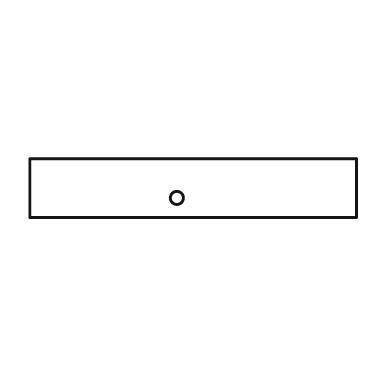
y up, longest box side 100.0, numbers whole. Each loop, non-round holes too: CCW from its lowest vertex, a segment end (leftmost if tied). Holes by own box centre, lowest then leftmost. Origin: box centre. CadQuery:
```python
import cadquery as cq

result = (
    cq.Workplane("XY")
    .moveTo(-50.0, -9.0)
    .lineTo(50.0, -9.0)
    .lineTo(50.0, 9.0)
    .lineTo(-50.0, 9.0)
    .close()
    .moveTo(-5.0, -3.0)
    .circle(2.0)
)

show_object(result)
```